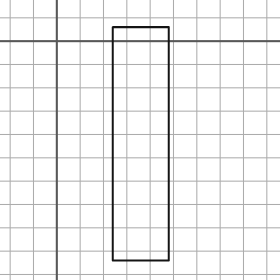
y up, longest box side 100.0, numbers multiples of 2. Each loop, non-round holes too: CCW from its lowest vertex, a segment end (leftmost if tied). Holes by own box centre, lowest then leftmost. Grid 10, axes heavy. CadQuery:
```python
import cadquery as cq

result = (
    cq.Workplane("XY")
    .moveTo(24.0, -94.0)
    .lineTo(48.0, -94.0)
    .lineTo(48.0, 6.0)
    .lineTo(24.0, 6.0)
    .close()
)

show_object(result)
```